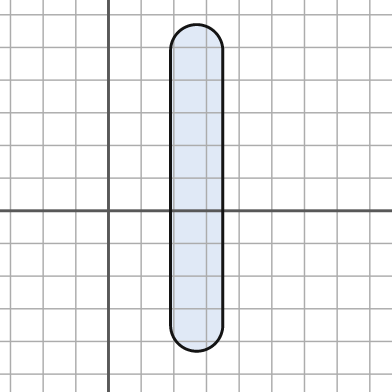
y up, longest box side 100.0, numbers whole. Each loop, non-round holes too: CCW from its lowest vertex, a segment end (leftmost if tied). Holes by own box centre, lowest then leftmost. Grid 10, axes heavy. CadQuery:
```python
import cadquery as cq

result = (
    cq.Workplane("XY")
    .moveTo(19.0, -35.0)
    .threePointArc((27.0, -43.0), (35.0, -35.0))
    .lineTo(35.0, 49.0)
    .threePointArc((27.0, 57.0), (19.0, 49.0))
    .close()
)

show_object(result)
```